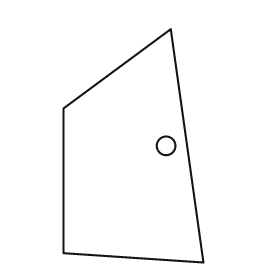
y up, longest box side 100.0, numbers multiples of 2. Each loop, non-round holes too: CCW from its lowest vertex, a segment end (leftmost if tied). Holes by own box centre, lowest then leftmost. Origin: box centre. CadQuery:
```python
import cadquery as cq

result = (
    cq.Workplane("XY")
    .moveTo(30.0, -50.0)
    .lineTo(16.0, 50.0)
    .lineTo(-30.0, 16.0)
    .lineTo(-30.0, -46.0)
    .close()
    .moveTo(14.0, 0.0)
    .circle(4.0)
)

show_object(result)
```